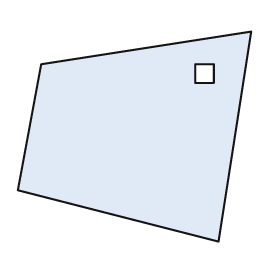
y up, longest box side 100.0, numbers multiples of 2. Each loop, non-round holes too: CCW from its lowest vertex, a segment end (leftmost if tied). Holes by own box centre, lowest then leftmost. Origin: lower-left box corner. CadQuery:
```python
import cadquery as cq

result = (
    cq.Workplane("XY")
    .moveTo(86.0, 0.0)
    .lineTo(100.0, 90.0)
    .lineTo(10.0, 76.0)
    .lineTo(0.0, 22.0)
    .close()
    .moveTo(76.0, 68.0)
    .lineTo(84.0, 68.0)
    .lineTo(84.0, 76.0)
    .lineTo(76.0, 76.0)
    .close()
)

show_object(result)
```